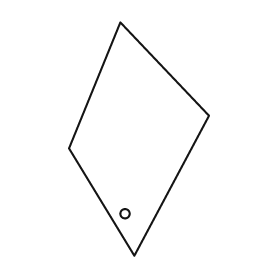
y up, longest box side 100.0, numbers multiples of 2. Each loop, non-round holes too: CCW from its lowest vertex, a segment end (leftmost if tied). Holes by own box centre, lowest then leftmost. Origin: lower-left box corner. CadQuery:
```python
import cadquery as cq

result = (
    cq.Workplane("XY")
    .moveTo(28.0, 0.0)
    .lineTo(60.0, 60.0)
    .lineTo(22.0, 100.0)
    .lineTo(0.0, 46.0)
    .close()
    .moveTo(24.0, 18.0)
    .circle(2.0)
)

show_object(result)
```